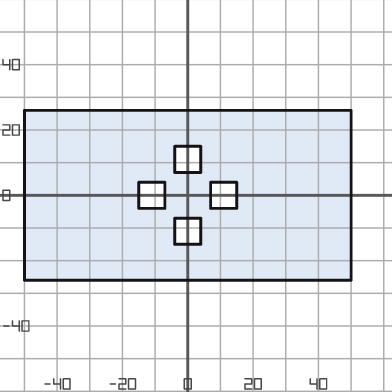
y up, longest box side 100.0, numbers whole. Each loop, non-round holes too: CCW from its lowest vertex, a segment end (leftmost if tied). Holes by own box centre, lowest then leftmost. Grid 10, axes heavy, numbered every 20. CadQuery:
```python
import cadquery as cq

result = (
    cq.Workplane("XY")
    .moveTo(-50.0, -26.0)
    .lineTo(50.0, -26.0)
    .lineTo(50.0, 26.0)
    .lineTo(-50.0, 26.0)
    .close()
    .moveTo(-4.0, -15.0)
    .lineTo(4.0, -15.0)
    .lineTo(4.0, -7.0)
    .lineTo(-4.0, -7.0)
    .close()
    .moveTo(-15.0, -4.0)
    .lineTo(-7.0, -4.0)
    .lineTo(-7.0, 4.0)
    .lineTo(-15.0, 4.0)
    .close()
    .moveTo(7.0, -4.0)
    .lineTo(15.0, -4.0)
    .lineTo(15.0, 4.0)
    .lineTo(7.0, 4.0)
    .close()
    .moveTo(-4.0, 7.0)
    .lineTo(4.0, 7.0)
    .lineTo(4.0, 15.0)
    .lineTo(-4.0, 15.0)
    .close()
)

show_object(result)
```